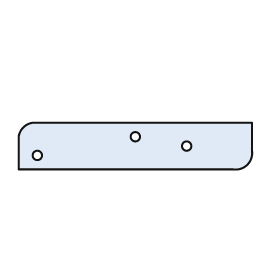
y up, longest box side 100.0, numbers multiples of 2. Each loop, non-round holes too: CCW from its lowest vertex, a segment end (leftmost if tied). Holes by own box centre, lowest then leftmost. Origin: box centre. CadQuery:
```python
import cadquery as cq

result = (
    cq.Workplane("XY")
    .moveTo(-50.0, -10.0)
    .lineTo(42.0, -10.0)
    .threePointArc((48.0, -8.0), (50.0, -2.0))
    .lineTo(50.0, 10.0)
    .lineTo(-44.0, 10.0)
    .threePointArc((-48.0, 8.0), (-50.0, 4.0))
    .close()
    .moveTo(-42.0, -4.0)
    .circle(2.0)
    .moveTo(22.0, 0.0)
    .circle(2.0)
    .moveTo(0.0, 4.0)
    .circle(2.0)
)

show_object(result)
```